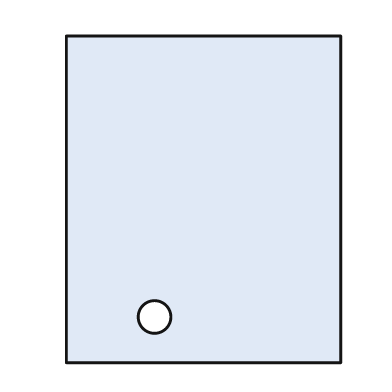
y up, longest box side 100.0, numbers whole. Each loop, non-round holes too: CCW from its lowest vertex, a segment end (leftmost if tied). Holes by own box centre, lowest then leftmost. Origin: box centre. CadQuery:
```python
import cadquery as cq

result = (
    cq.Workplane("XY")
    .moveTo(-42.0, -50.0)
    .lineTo(42.0, -50.0)
    .lineTo(42.0, 50.0)
    .lineTo(-42.0, 50.0)
    .close()
    .moveTo(-15.0, -36.0)
    .circle(5.0)
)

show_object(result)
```